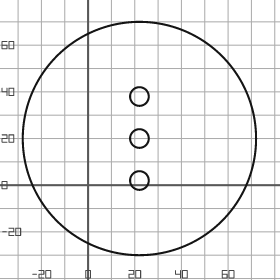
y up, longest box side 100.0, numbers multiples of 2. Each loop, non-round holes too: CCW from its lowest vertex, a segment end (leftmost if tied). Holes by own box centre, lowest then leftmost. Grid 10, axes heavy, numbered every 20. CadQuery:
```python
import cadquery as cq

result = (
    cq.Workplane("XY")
    .moveTo(22.0, 20.0)
    .circle(50.0)
    .moveTo(22.0, 2.0)
    .circle(4.0)
    .moveTo(22.0, 20.0)
    .circle(4.0)
    .moveTo(22.0, 38.0)
    .circle(4.0)
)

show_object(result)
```